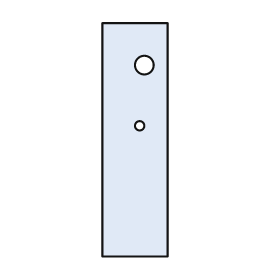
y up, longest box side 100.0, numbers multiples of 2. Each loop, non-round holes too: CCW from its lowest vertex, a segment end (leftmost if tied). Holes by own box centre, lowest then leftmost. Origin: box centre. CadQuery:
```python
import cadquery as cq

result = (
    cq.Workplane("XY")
    .moveTo(-14.0, -50.0)
    .lineTo(14.0, -50.0)
    .lineTo(14.0, 50.0)
    .lineTo(-14.0, 50.0)
    .close()
    .moveTo(2.0, 6.0)
    .circle(2.0)
    .moveTo(4.0, 32.0)
    .circle(4.0)
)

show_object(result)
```